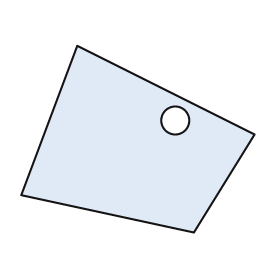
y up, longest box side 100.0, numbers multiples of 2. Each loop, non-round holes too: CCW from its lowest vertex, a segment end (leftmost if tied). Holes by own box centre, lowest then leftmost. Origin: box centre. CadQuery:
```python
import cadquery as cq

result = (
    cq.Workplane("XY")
    .moveTo(24.0, -40.0)
    .lineTo(50.0, 2.0)
    .lineTo(-26.0, 40.0)
    .lineTo(-50.0, -24.0)
    .close()
    .moveTo(16.0, 8.0)
    .circle(6.0)
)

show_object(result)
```